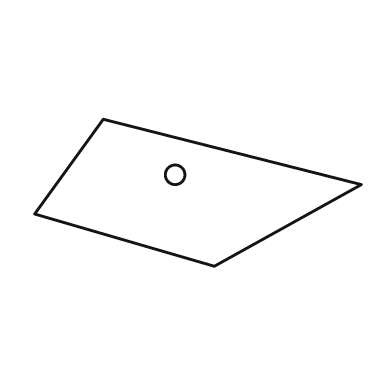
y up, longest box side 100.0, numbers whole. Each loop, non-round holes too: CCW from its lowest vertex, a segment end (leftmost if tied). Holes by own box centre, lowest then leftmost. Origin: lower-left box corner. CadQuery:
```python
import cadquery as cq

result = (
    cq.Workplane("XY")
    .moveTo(55.0, 0.0)
    .lineTo(100.0, 25.0)
    .lineTo(21.0, 45.0)
    .lineTo(0.0, 16.0)
    .close()
    .moveTo(43.0, 28.0)
    .circle(3.0)
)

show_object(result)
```